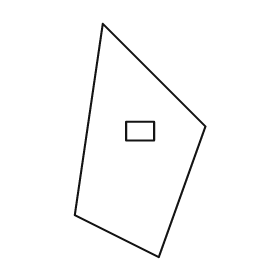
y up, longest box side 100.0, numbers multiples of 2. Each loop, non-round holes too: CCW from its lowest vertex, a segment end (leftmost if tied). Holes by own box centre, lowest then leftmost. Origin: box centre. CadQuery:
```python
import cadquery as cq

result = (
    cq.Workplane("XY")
    .moveTo(8.0, -50.0)
    .lineTo(28.0, 6.0)
    .lineTo(-16.0, 50.0)
    .lineTo(-28.0, -32.0)
    .close()
    .moveTo(-6.0, 0.0)
    .lineTo(6.0, 0.0)
    .lineTo(6.0, 8.0)
    .lineTo(-6.0, 8.0)
    .close()
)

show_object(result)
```